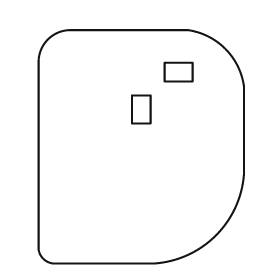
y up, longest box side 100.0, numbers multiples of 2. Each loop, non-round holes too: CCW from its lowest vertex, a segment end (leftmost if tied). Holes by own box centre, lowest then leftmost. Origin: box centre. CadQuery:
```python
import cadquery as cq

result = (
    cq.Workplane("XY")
    .moveTo(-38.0, -50.0)
    .lineTo(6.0, -50.0)
    .threePointArc((32.0, -38.0), (44.0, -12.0))
    .lineTo(44.0, 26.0)
    .threePointArc((36.0, 42.0), (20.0, 50.0))
    .lineTo(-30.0, 50.0)
    .threePointArc((-40.0, 46.0), (-44.0, 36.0))
    .lineTo(-44.0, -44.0)
    .threePointArc((-42.0, -48.0), (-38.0, -50.0))
    .close()
    .moveTo(-4.0, 10.0)
    .lineTo(4.0, 10.0)
    .lineTo(4.0, 22.0)
    .lineTo(-4.0, 22.0)
    .close()
    .moveTo(10.0, 28.0)
    .lineTo(22.0, 28.0)
    .lineTo(22.0, 36.0)
    .lineTo(10.0, 36.0)
    .close()
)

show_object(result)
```